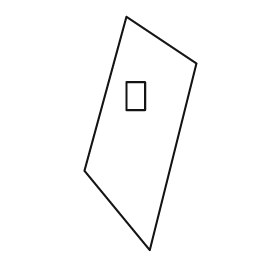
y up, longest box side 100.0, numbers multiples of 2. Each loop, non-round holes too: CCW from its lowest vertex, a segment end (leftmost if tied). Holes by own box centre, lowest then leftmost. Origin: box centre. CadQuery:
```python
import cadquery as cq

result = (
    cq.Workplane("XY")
    .moveTo(4.0, -50.0)
    .lineTo(24.0, 30.0)
    .lineTo(-6.0, 50.0)
    .lineTo(-24.0, -16.0)
    .close()
    .moveTo(-6.0, 10.0)
    .lineTo(2.0, 10.0)
    .lineTo(2.0, 22.0)
    .lineTo(-6.0, 22.0)
    .close()
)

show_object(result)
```